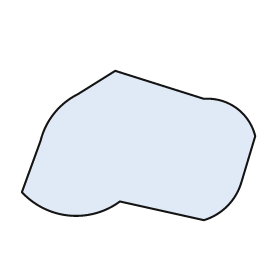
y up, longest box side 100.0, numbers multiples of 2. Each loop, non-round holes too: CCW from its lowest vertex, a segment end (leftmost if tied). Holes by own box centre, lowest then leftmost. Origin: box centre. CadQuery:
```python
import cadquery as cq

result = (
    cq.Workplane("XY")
    .moveTo(28.0, -32.0)
    .threePointArc((38.0, -26.0), (44.0, -16.0))
    .lineTo(50.0, 4.0)
    .threePointArc((42.0, 16.0), (28.0, 20.0))
    .lineTo(-10.0, 32.0)
    .lineTo(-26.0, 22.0)
    .threePointArc((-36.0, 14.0), (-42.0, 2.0))
    .lineTo(-50.0, -20.0)
    .threePointArc((-30.0, -30.0), (-8.0, -24.0))
    .close()
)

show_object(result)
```